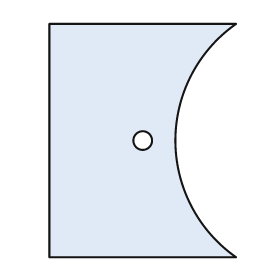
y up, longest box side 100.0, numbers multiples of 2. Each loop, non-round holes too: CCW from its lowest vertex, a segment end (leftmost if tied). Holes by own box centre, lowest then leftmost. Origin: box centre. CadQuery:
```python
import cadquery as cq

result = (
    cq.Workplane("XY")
    .moveTo(-40.0, -50.0)
    .lineTo(40.0, -50.0)
    .threePointArc((14.0, 0.0), (40.0, 50.0))
    .lineTo(-40.0, 50.0)
    .close()
    .moveTo(0.0, 0.0)
    .circle(4.0)
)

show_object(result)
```